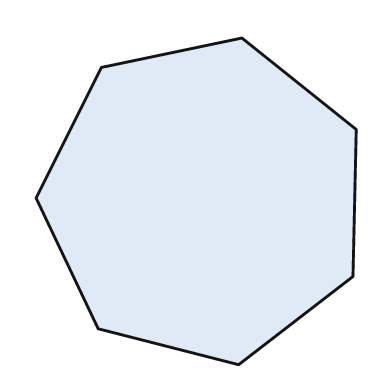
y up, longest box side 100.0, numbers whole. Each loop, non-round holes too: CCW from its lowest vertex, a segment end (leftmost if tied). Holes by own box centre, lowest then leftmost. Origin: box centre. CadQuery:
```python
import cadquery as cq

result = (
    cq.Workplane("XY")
    .moveTo(13.0, -50.0)
    .lineTo(48.0, -23.0)
    .lineTo(49.0, 22.0)
    .lineTo(14.0, 50.0)
    .lineTo(-29.0, 41.0)
    .lineTo(-49.0, 1.0)
    .lineTo(-30.0, -39.0)
    .close()
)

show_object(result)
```